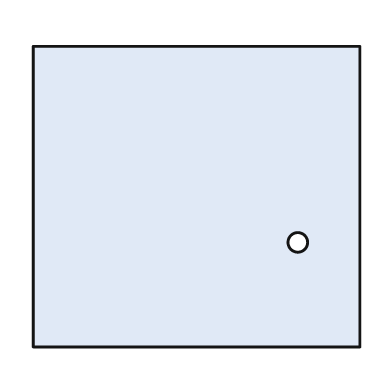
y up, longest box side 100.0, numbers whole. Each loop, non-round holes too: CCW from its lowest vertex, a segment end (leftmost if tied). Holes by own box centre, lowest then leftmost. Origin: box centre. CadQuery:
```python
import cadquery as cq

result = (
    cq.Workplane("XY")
    .moveTo(-50.0, -46.0)
    .lineTo(50.0, -46.0)
    .lineTo(50.0, 46.0)
    .lineTo(-50.0, 46.0)
    .close()
    .moveTo(31.0, -14.0)
    .circle(3.0)
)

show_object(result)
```